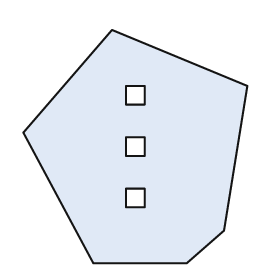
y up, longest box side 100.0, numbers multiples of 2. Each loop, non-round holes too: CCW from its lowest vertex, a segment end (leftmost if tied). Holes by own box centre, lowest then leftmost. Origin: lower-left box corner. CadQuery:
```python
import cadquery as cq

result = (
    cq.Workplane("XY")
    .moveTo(30.0, 0.0)
    .lineTo(70.0, 0.0)
    .lineTo(86.0, 14.0)
    .lineTo(96.0, 76.0)
    .lineTo(38.0, 100.0)
    .lineTo(0.0, 56.0)
    .close()
    .moveTo(44.0, 24.0)
    .lineTo(52.0, 24.0)
    .lineTo(52.0, 32.0)
    .lineTo(44.0, 32.0)
    .close()
    .moveTo(44.0, 46.0)
    .lineTo(52.0, 46.0)
    .lineTo(52.0, 54.0)
    .lineTo(44.0, 54.0)
    .close()
    .moveTo(44.0, 68.0)
    .lineTo(52.0, 68.0)
    .lineTo(52.0, 76.0)
    .lineTo(44.0, 76.0)
    .close()
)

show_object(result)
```